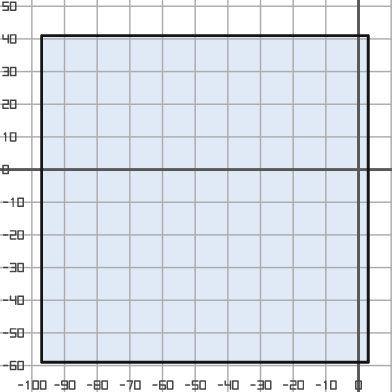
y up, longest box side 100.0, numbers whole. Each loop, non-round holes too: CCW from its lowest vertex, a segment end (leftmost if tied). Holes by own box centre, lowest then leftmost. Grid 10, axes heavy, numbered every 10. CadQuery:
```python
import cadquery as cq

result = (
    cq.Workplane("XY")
    .moveTo(-97.0, -59.0)
    .lineTo(3.0, -59.0)
    .lineTo(3.0, 41.0)
    .lineTo(-97.0, 41.0)
    .close()
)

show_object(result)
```